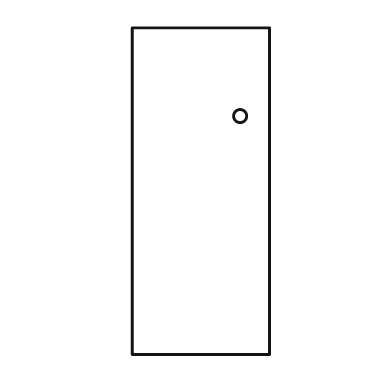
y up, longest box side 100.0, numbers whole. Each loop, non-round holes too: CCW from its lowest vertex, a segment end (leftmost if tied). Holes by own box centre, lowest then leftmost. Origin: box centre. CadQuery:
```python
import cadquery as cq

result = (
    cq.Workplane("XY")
    .moveTo(-21.0, -50.0)
    .lineTo(21.0, -50.0)
    .lineTo(21.0, 50.0)
    .lineTo(-21.0, 50.0)
    .close()
    .moveTo(12.0, 23.0)
    .circle(2.0)
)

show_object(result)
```